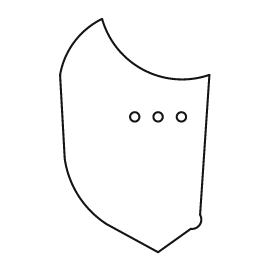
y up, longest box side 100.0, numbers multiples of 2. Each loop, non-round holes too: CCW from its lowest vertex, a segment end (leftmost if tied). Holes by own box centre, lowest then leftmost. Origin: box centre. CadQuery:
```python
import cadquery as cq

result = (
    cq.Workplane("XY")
    .moveTo(10.0, -50.0)
    .lineTo(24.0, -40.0)
    .threePointArc((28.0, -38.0), (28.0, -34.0))
    .lineTo(32.0, 26.0)
    .threePointArc((4.0, 28.0), (-14.0, 50.0))
    .threePointArc((-26.0, 40.0), (-32.0, 26.0))
    .lineTo(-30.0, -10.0)
    .threePointArc((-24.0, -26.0), (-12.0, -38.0))
    .close()
    .moveTo(0.0, 8.0)
    .circle(2.0)
    .moveTo(10.0, 8.0)
    .circle(2.0)
    .moveTo(20.0, 8.0)
    .circle(2.0)
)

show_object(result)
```